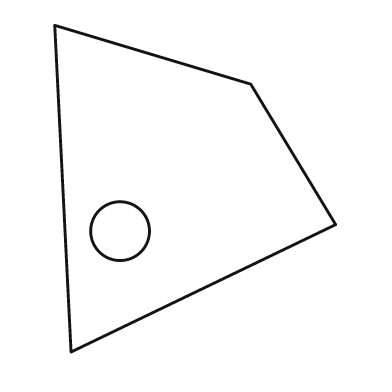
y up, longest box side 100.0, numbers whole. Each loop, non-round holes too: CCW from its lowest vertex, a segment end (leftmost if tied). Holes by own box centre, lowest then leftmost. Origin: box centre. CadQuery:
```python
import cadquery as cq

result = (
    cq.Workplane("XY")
    .moveTo(-38.0, -50.0)
    .lineTo(43.0, -11.0)
    .lineTo(17.0, 32.0)
    .lineTo(-43.0, 50.0)
    .close()
    .moveTo(-23.0, -13.0)
    .circle(9.0)
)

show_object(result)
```